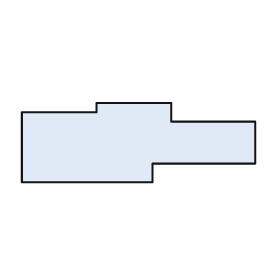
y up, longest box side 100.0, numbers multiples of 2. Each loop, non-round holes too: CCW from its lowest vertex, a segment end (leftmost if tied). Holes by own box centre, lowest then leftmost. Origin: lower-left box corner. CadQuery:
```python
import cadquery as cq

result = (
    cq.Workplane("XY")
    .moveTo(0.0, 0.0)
    .lineTo(56.0, 0.0)
    .lineTo(56.0, 8.0)
    .lineTo(100.0, 8.0)
    .lineTo(100.0, 26.0)
    .lineTo(64.0, 26.0)
    .lineTo(64.0, 34.0)
    .lineTo(32.0, 34.0)
    .lineTo(32.0, 30.0)
    .lineTo(0.0, 30.0)
    .close()
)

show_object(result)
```